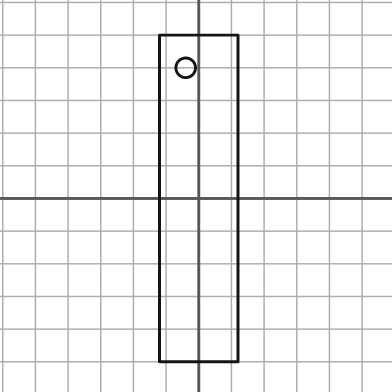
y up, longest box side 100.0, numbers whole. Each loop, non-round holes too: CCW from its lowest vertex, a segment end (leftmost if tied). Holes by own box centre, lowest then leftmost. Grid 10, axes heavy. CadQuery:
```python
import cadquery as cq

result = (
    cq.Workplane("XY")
    .moveTo(-12.0, -50.0)
    .lineTo(12.0, -50.0)
    .lineTo(12.0, 50.0)
    .lineTo(-12.0, 50.0)
    .close()
    .moveTo(-4.0, 40.0)
    .circle(3.0)
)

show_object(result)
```